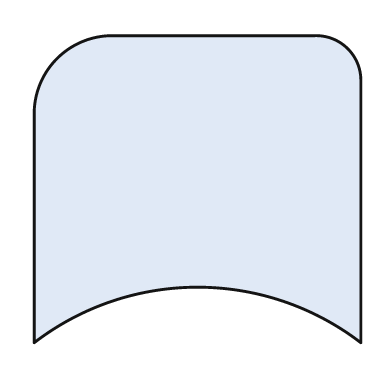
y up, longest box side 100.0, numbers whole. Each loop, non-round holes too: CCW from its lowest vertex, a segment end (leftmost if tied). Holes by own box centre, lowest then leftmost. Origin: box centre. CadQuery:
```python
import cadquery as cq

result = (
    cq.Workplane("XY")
    .moveTo(-50.0, -47.0)
    .threePointArc((0.0, -30.0), (50.0, -47.0))
    .lineTo(50.0, 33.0)
    .threePointArc((46.0, 43.0), (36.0, 47.0))
    .lineTo(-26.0, 47.0)
    .threePointArc((-43.0, 40.0), (-50.0, 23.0))
    .close()
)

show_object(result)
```